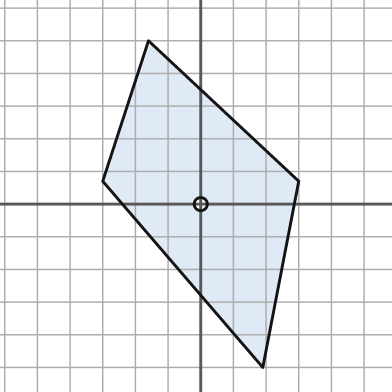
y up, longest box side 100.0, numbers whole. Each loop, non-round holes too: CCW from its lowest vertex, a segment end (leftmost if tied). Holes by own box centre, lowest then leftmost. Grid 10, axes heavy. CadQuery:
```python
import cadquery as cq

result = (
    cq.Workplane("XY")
    .moveTo(19.0, -50.0)
    .lineTo(30.0, 7.0)
    .lineTo(-16.0, 50.0)
    .lineTo(-30.0, 7.0)
    .close()
    .moveTo(0.0, 0.0)
    .circle(2.0)
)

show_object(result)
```